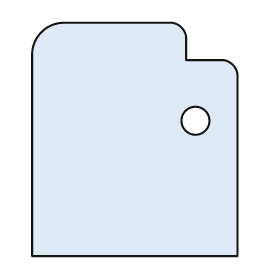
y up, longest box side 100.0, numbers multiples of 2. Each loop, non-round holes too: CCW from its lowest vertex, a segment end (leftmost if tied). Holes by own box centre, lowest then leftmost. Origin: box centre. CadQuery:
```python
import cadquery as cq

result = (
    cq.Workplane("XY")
    .moveTo(-44.0, -50.0)
    .lineTo(44.0, -50.0)
    .lineTo(44.0, 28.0)
    .threePointArc((42.0, 32.0), (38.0, 34.0))
    .lineTo(22.0, 34.0)
    .lineTo(22.0, 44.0)
    .threePointArc((20.0, 48.0), (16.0, 50.0))
    .lineTo(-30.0, 50.0)
    .threePointArc((-40.0, 46.0), (-44.0, 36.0))
    .close()
    .moveTo(26.0, 8.0)
    .circle(6.0)
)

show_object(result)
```